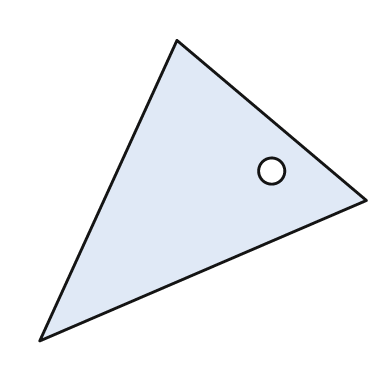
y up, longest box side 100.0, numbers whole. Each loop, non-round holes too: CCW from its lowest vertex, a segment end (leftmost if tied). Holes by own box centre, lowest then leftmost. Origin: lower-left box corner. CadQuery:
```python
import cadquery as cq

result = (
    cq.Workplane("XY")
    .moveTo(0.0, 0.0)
    .lineTo(100.0, 43.0)
    .lineTo(42.0, 92.0)
    .close()
    .moveTo(71.0, 52.0)
    .circle(4.0)
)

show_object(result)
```